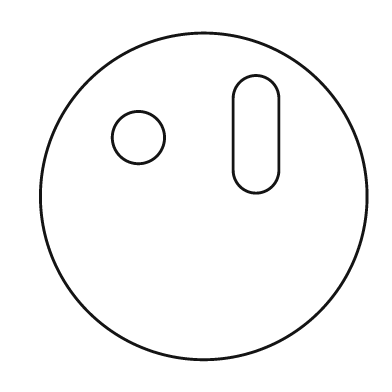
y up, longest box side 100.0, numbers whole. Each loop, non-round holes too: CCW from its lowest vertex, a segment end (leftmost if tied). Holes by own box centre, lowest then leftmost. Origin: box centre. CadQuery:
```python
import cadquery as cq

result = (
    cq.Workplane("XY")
    .moveTo(0.0, 0.0)
    .circle(50.0)
    .moveTo(-20.0, 18.0)
    .circle(8.0)
    .moveTo(9.0, 8.0)
    .threePointArc((16.0, 1.0), (23.0, 8.0))
    .lineTo(23.0, 30.0)
    .threePointArc((16.0, 37.0), (9.0, 30.0))
    .close()
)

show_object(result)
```